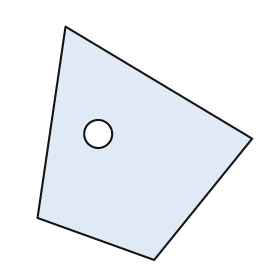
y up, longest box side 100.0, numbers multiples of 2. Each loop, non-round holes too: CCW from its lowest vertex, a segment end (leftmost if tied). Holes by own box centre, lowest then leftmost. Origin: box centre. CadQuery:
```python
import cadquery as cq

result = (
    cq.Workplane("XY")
    .moveTo(4.0, -50.0)
    .lineTo(46.0, 2.0)
    .lineTo(-34.0, 50.0)
    .lineTo(-46.0, -32.0)
    .close()
    .moveTo(-20.0, 4.0)
    .circle(6.0)
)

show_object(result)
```